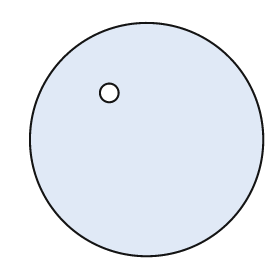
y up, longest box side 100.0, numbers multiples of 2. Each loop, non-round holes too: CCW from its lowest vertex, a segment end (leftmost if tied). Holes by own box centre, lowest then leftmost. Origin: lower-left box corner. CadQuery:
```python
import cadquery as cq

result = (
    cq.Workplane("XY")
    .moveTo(50.0, 50.0)
    .circle(50.0)
    .moveTo(34.0, 70.0)
    .circle(4.0)
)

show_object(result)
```